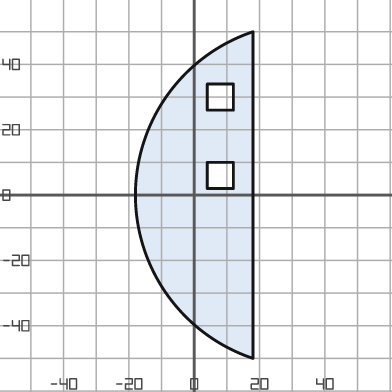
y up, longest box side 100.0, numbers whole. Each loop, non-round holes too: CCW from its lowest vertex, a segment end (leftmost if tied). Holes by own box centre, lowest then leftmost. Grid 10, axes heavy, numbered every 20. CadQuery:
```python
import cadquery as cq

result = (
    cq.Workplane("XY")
    .moveTo(18.0, -50.0)
    .lineTo(18.0, 50.0)
    .threePointArc((-18.0, 0.0), (18.0, -50.0))
    .close()
    .moveTo(4.0, 2.0)
    .lineTo(12.0, 2.0)
    .lineTo(12.0, 10.0)
    .lineTo(4.0, 10.0)
    .close()
    .moveTo(4.0, 26.0)
    .lineTo(12.0, 26.0)
    .lineTo(12.0, 34.0)
    .lineTo(4.0, 34.0)
    .close()
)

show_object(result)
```